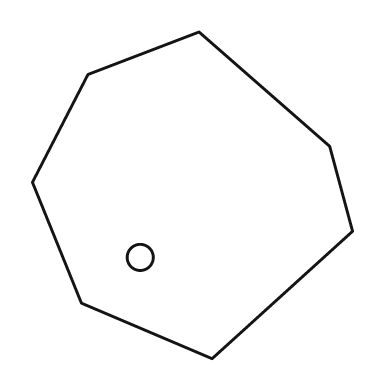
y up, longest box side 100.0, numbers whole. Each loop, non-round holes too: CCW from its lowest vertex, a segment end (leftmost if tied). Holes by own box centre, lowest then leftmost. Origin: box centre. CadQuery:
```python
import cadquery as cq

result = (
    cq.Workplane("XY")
    .moveTo(6.0, -50.0)
    .lineTo(49.0, -11.0)
    .lineTo(42.0, 15.0)
    .lineTo(2.0, 50.0)
    .lineTo(-32.0, 37.0)
    .lineTo(-49.0, 4.0)
    .lineTo(-34.0, -33.0)
    .close()
    .moveTo(-16.0, -19.0)
    .circle(4.0)
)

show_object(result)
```